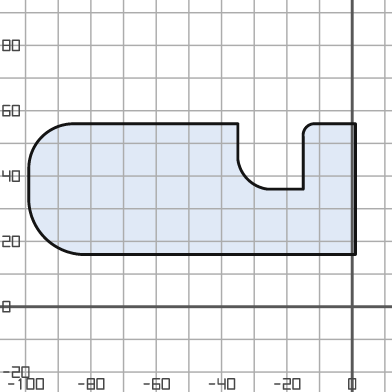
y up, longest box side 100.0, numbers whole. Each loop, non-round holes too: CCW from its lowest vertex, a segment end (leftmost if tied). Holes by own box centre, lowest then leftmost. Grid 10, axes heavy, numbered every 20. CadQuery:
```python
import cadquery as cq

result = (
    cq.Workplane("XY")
    .moveTo(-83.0, 16.0)
    .lineTo(1.0, 16.0)
    .lineTo(1.0, 56.0)
    .lineTo(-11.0, 56.0)
    .threePointArc((-14.0, 55.0), (-15.0, 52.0))
    .lineTo(-15.0, 36.0)
    .lineTo(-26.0, 36.0)
    .threePointArc((-32.0, 39.0), (-35.0, 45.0))
    .lineTo(-35.0, 56.0)
    .lineTo(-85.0, 56.0)
    .threePointArc((-95.0, 52.0), (-99.0, 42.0))
    .lineTo(-99.0, 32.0)
    .threePointArc((-94.0, 21.0), (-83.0, 16.0))
    .close()
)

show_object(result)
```